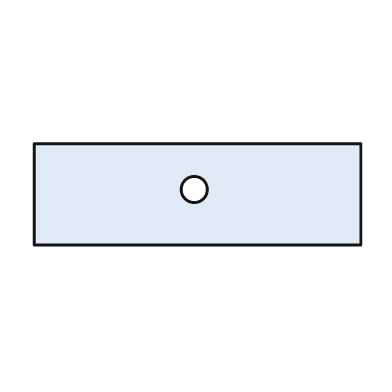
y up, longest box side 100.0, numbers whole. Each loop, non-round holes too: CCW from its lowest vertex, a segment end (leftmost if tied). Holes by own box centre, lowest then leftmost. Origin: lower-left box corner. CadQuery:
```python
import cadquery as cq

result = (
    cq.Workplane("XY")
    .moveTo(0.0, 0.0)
    .lineTo(100.0, 0.0)
    .lineTo(100.0, 31.0)
    .lineTo(0.0, 31.0)
    .close()
    .moveTo(49.0, 17.0)
    .circle(4.0)
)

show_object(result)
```